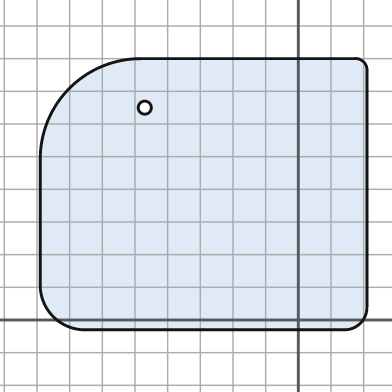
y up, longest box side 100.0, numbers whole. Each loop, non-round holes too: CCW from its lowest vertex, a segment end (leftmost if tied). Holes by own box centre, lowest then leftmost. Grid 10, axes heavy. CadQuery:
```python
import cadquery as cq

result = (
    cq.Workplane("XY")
    .moveTo(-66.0, -3.0)
    .lineTo(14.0, -3.0)
    .threePointArc((19.0, -1.0), (21.0, 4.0))
    .lineTo(21.0, 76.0)
    .threePointArc((20.0, 79.0), (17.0, 80.0))
    .lineTo(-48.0, 80.0)
    .threePointArc((-70.0, 71.0), (-79.0, 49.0))
    .lineTo(-79.0, 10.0)
    .threePointArc((-75.0, 1.0), (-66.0, -3.0))
    .close()
    .moveTo(-47.0, 65.0)
    .circle(2.0)
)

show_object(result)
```